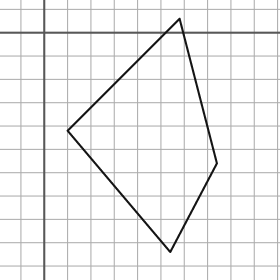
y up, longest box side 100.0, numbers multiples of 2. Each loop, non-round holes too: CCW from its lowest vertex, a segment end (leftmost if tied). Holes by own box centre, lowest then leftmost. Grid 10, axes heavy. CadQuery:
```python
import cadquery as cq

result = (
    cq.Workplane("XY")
    .moveTo(54.0, -94.0)
    .lineTo(74.0, -56.0)
    .lineTo(58.0, 6.0)
    .lineTo(10.0, -42.0)
    .close()
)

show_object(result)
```